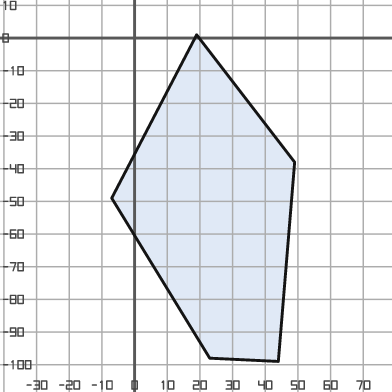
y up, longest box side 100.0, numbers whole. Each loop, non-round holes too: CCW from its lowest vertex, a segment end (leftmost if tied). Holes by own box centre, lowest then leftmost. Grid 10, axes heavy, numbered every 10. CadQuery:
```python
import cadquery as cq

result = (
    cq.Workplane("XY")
    .moveTo(44.0, -99.0)
    .lineTo(49.0, -38.0)
    .lineTo(19.0, 1.0)
    .lineTo(-7.0, -49.0)
    .lineTo(23.0, -98.0)
    .close()
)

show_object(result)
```